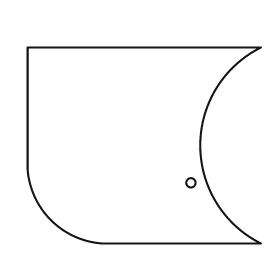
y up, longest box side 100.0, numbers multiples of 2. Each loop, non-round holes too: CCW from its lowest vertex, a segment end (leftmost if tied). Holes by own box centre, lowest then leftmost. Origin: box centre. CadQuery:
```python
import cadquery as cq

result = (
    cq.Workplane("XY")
    .moveTo(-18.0, -42.0)
    .lineTo(50.0, -42.0)
    .threePointArc((24.0, 0.0), (50.0, 42.0))
    .lineTo(-50.0, 42.0)
    .lineTo(-50.0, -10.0)
    .threePointArc((-40.0, -32.0), (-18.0, -42.0))
    .close()
    .moveTo(20.0, -16.0)
    .circle(2.0)
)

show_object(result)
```